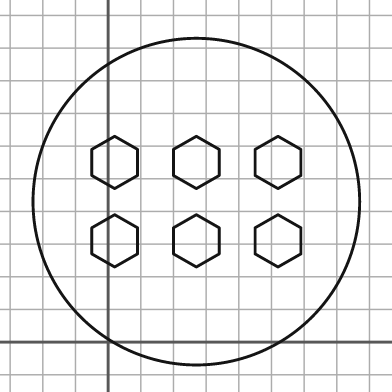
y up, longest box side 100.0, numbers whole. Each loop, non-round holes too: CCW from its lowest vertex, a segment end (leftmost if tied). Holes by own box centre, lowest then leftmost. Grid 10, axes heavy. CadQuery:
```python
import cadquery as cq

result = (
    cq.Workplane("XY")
    .moveTo(27.0, 43.0)
    .circle(50.0)
    .moveTo(2.0, 23.0)
    .lineTo(9.0, 27.0)
    .lineTo(9.0, 35.0)
    .lineTo(2.0, 39.0)
    .lineTo(-5.0, 35.0)
    .lineTo(-5.0, 27.0)
    .close()
    .moveTo(27.0, 23.0)
    .lineTo(34.0, 27.0)
    .lineTo(34.0, 35.0)
    .lineTo(27.0, 39.0)
    .lineTo(20.0, 35.0)
    .lineTo(20.0, 27.0)
    .close()
    .moveTo(52.0, 23.0)
    .lineTo(59.0, 27.0)
    .lineTo(59.0, 35.0)
    .lineTo(52.0, 39.0)
    .lineTo(45.0, 35.0)
    .lineTo(45.0, 27.0)
    .close()
    .moveTo(2.0, 47.0)
    .lineTo(9.0, 51.0)
    .lineTo(9.0, 59.0)
    .lineTo(2.0, 63.0)
    .lineTo(-5.0, 59.0)
    .lineTo(-5.0, 51.0)
    .close()
    .moveTo(27.0, 47.0)
    .lineTo(34.0, 51.0)
    .lineTo(34.0, 59.0)
    .lineTo(27.0, 63.0)
    .lineTo(20.0, 59.0)
    .lineTo(20.0, 51.0)
    .close()
    .moveTo(52.0, 47.0)
    .lineTo(59.0, 51.0)
    .lineTo(59.0, 59.0)
    .lineTo(52.0, 63.0)
    .lineTo(45.0, 59.0)
    .lineTo(45.0, 51.0)
    .close()
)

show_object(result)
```